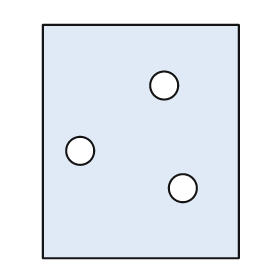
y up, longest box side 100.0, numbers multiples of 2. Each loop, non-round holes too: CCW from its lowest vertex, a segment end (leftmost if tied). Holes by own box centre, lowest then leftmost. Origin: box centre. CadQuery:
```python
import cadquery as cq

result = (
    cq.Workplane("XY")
    .moveTo(-42.0, -50.0)
    .lineTo(42.0, -50.0)
    .lineTo(42.0, 50.0)
    .lineTo(-42.0, 50.0)
    .close()
    .moveTo(18.0, -20.0)
    .circle(6.0)
    .moveTo(-26.0, -4.0)
    .circle(6.0)
    .moveTo(10.0, 24.0)
    .circle(6.0)
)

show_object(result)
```